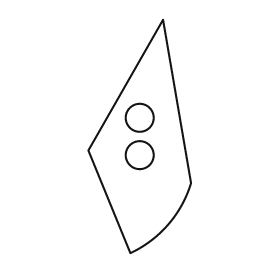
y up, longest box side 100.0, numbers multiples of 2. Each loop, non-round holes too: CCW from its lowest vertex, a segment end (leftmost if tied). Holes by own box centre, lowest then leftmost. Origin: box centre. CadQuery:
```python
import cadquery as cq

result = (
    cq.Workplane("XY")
    .moveTo(-4.0, -50.0)
    .threePointArc((12.0, -38.0), (22.0, -20.0))
    .lineTo(10.0, 50.0)
    .lineTo(-22.0, -6.0)
    .close()
    .moveTo(0.0, -8.0)
    .circle(6.0)
    .moveTo(0.0, 8.0)
    .circle(6.0)
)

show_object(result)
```